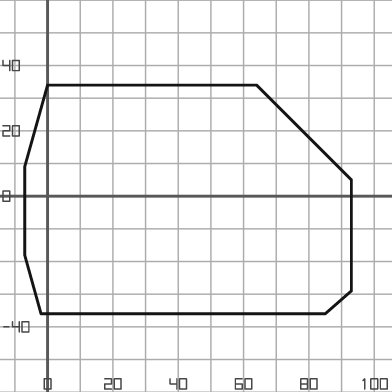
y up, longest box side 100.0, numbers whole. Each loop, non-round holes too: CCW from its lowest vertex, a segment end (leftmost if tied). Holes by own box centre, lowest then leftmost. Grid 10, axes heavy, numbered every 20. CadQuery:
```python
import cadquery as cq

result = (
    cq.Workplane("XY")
    .moveTo(-2.0, -36.0)
    .lineTo(85.0, -36.0)
    .lineTo(93.0, -29.0)
    .lineTo(93.0, 5.0)
    .lineTo(64.0, 34.0)
    .lineTo(0.0, 34.0)
    .lineTo(-7.0, 9.0)
    .lineTo(-7.0, -18.0)
    .close()
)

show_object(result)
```